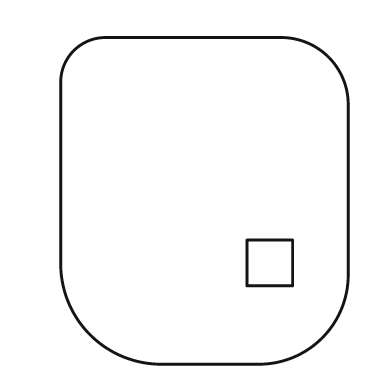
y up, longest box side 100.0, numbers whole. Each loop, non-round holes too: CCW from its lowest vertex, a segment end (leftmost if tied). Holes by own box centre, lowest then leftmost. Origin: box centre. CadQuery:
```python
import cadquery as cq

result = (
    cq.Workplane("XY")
    .moveTo(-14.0, -50.0)
    .lineTo(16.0, -50.0)
    .threePointArc((36.0, -42.0), (44.0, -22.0))
    .lineTo(44.0, 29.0)
    .threePointArc((38.0, 44.0), (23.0, 50.0))
    .lineTo(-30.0, 50.0)
    .threePointArc((-40.0, 46.0), (-44.0, 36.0))
    .lineTo(-44.0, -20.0)
    .threePointArc((-35.0, -41.0), (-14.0, -50.0))
    .close()
    .moveTo(13.0, -26.0)
    .lineTo(27.0, -26.0)
    .lineTo(27.0, -12.0)
    .lineTo(13.0, -12.0)
    .close()
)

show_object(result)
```